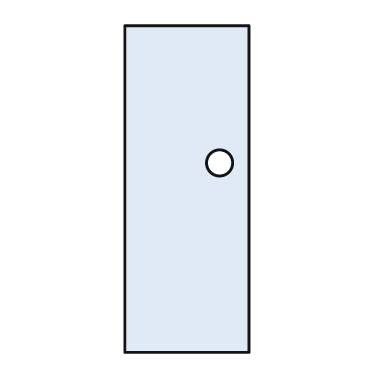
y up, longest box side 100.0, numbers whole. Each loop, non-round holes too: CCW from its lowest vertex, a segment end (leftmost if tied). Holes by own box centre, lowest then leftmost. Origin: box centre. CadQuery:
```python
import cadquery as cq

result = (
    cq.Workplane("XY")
    .moveTo(-19.0, -50.0)
    .lineTo(19.0, -50.0)
    .lineTo(19.0, 50.0)
    .lineTo(-19.0, 50.0)
    .close()
    .moveTo(10.0, 8.0)
    .circle(4.0)
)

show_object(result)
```